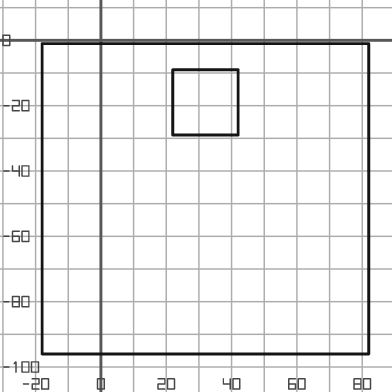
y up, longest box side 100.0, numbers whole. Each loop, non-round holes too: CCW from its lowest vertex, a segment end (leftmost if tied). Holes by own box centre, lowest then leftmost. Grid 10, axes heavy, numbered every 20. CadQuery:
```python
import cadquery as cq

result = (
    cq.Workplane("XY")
    .moveTo(-18.0, -96.0)
    .lineTo(82.0, -96.0)
    .lineTo(82.0, -1.0)
    .lineTo(-18.0, -1.0)
    .close()
    .moveTo(22.0, -29.0)
    .lineTo(42.0, -29.0)
    .lineTo(42.0, -9.0)
    .lineTo(22.0, -9.0)
    .close()
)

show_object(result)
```